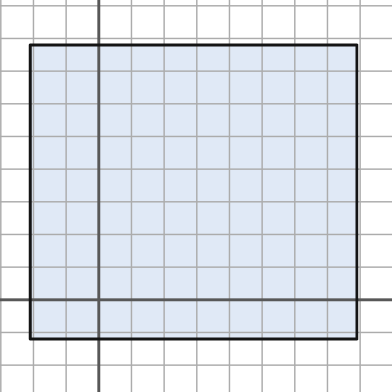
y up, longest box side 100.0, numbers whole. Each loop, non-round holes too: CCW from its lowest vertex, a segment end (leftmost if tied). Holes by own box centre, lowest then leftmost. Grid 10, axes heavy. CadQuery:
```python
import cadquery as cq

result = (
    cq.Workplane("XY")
    .moveTo(-21.0, -12.0)
    .lineTo(79.0, -12.0)
    .lineTo(79.0, 78.0)
    .lineTo(-21.0, 78.0)
    .close()
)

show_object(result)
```